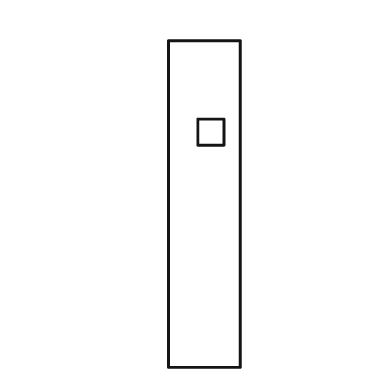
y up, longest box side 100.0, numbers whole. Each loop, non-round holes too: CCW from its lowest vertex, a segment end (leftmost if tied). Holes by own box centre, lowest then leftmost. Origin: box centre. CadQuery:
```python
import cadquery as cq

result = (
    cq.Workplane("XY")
    .moveTo(-11.0, -50.0)
    .lineTo(11.0, -50.0)
    .lineTo(11.0, 50.0)
    .lineTo(-11.0, 50.0)
    .close()
    .moveTo(-2.0, 18.0)
    .lineTo(6.0, 18.0)
    .lineTo(6.0, 26.0)
    .lineTo(-2.0, 26.0)
    .close()
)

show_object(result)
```